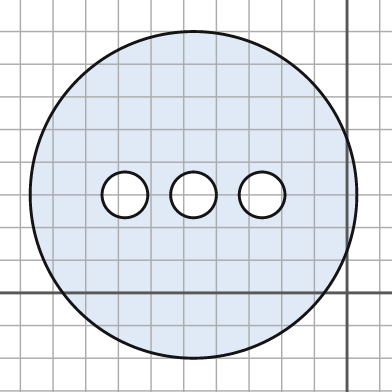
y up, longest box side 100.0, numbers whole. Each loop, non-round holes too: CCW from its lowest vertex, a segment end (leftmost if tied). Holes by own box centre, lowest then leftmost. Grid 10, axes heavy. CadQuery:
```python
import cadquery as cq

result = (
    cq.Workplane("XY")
    .moveTo(-47.0, 30.0)
    .circle(50.0)
    .moveTo(-68.0, 30.0)
    .circle(7.0)
    .moveTo(-47.0, 30.0)
    .circle(7.0)
    .moveTo(-26.0, 30.0)
    .circle(7.0)
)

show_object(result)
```